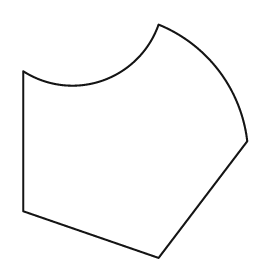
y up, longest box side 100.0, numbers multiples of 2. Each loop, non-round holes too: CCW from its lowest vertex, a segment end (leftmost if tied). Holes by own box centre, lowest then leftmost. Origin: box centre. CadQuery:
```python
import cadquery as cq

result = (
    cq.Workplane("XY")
    .moveTo(10.0, -50.0)
    .lineTo(48.0, 0.0)
    .threePointArc((36.0, 30.0), (10.0, 50.0))
    .threePointArc((-14.0, 26.0), (-48.0, 30.0))
    .lineTo(-48.0, -30.0)
    .close()
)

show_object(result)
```